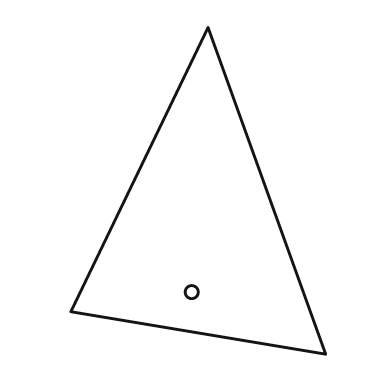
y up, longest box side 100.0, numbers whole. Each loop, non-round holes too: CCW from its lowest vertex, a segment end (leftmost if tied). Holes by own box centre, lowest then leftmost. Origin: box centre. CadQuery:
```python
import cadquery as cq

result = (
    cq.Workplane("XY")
    .moveTo(39.0, -50.0)
    .lineTo(3.0, 50.0)
    .lineTo(-39.0, -37.0)
    .close()
    .moveTo(-2.0, -31.0)
    .circle(2.0)
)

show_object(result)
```